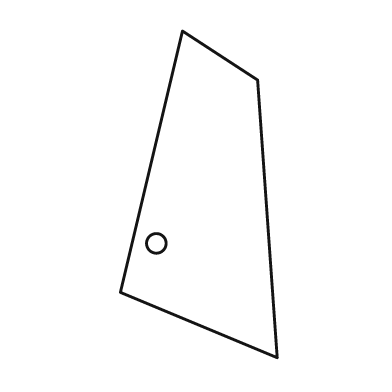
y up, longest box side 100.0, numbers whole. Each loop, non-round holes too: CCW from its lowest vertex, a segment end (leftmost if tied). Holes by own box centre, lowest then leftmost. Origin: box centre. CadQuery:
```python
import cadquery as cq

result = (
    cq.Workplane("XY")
    .moveTo(24.0, -50.0)
    .lineTo(18.0, 35.0)
    .lineTo(-5.0, 50.0)
    .lineTo(-24.0, -30.0)
    .close()
    .moveTo(-13.0, -15.0)
    .circle(3.0)
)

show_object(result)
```